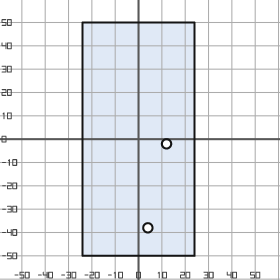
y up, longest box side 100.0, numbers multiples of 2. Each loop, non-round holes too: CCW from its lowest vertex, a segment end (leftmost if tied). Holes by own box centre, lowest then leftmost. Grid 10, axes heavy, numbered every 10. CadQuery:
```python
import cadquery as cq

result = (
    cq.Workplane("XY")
    .moveTo(-24.0, -50.0)
    .lineTo(24.0, -50.0)
    .lineTo(24.0, 50.0)
    .lineTo(-24.0, 50.0)
    .close()
    .moveTo(4.0, -38.0)
    .circle(2.0)
    .moveTo(12.0, -2.0)
    .circle(2.0)
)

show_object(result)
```